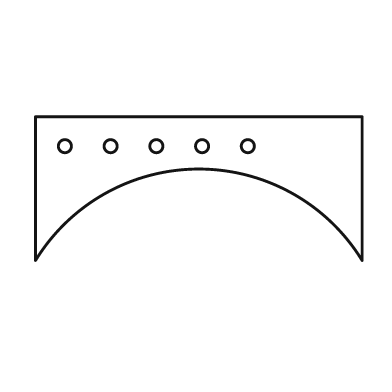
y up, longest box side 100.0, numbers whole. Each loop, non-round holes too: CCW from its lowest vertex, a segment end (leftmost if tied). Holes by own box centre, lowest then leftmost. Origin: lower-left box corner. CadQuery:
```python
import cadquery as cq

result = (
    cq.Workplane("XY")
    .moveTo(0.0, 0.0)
    .threePointArc((50.0, 28.0), (100.0, 0.0))
    .lineTo(100.0, 44.0)
    .lineTo(0.0, 44.0)
    .close()
    .moveTo(9.0, 35.0)
    .circle(2.0)
    .moveTo(23.0, 35.0)
    .circle(2.0)
    .moveTo(37.0, 35.0)
    .circle(2.0)
    .moveTo(51.0, 35.0)
    .circle(2.0)
    .moveTo(65.0, 35.0)
    .circle(2.0)
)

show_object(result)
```